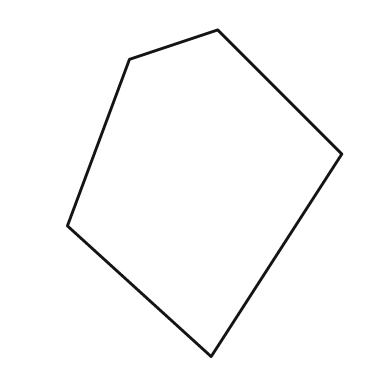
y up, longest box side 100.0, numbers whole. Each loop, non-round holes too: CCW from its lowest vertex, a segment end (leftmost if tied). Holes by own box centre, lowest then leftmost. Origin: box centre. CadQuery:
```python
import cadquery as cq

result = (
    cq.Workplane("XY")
    .moveTo(2.0, -50.0)
    .lineTo(42.0, 12.0)
    .lineTo(4.0, 50.0)
    .lineTo(-23.0, 41.0)
    .lineTo(-42.0, -10.0)
    .close()
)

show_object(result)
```